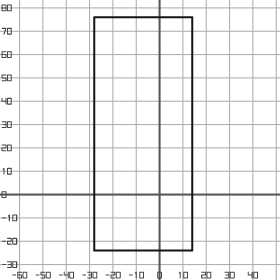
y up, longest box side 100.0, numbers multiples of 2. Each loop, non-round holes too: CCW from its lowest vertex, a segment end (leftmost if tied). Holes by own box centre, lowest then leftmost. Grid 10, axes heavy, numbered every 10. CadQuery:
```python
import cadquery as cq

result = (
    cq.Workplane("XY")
    .moveTo(-28.0, -24.0)
    .lineTo(14.0, -24.0)
    .lineTo(14.0, 76.0)
    .lineTo(-28.0, 76.0)
    .close()
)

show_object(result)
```